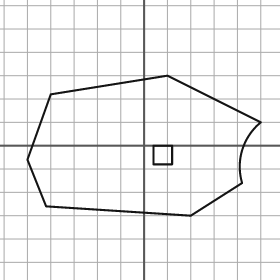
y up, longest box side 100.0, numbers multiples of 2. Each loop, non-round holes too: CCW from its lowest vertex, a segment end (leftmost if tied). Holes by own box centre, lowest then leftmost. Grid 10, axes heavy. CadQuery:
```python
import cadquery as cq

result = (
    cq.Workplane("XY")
    .moveTo(20.0, -30.0)
    .lineTo(42.0, -16.0)
    .threePointArc((42.0, -2.0), (50.0, 10.0))
    .lineTo(10.0, 30.0)
    .lineTo(-40.0, 22.0)
    .lineTo(-50.0, -6.0)
    .lineTo(-42.0, -26.0)
    .close()
    .moveTo(4.0, -8.0)
    .lineTo(12.0, -8.0)
    .lineTo(12.0, 0.0)
    .lineTo(4.0, 0.0)
    .close()
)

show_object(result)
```